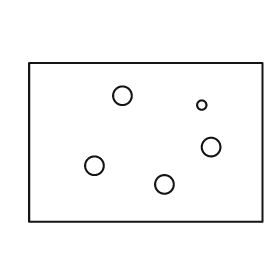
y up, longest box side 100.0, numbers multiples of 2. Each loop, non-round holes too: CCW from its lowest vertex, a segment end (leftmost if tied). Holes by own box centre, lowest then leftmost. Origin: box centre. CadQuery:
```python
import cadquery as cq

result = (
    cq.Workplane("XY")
    .moveTo(-50.0, -34.0)
    .lineTo(50.0, -34.0)
    .lineTo(50.0, 34.0)
    .lineTo(-50.0, 34.0)
    .close()
    .moveTo(8.0, -18.0)
    .circle(4.0)
    .moveTo(-22.0, -10.0)
    .circle(4.0)
    .moveTo(28.0, -2.0)
    .circle(4.0)
    .moveTo(24.0, 16.0)
    .circle(2.0)
    .moveTo(-10.0, 20.0)
    .circle(4.0)
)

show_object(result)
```